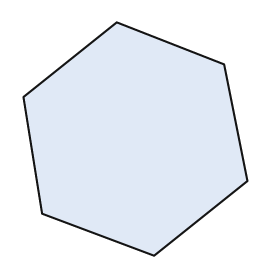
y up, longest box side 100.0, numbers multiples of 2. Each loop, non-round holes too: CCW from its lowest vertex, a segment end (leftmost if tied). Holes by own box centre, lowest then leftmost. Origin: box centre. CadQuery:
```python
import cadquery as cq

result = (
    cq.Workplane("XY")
    .moveTo(8.0, -50.0)
    .lineTo(48.0, -18.0)
    .lineTo(38.0, 32.0)
    .lineTo(-8.0, 50.0)
    .lineTo(-48.0, 18.0)
    .lineTo(-40.0, -32.0)
    .close()
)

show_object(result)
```